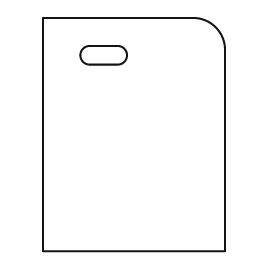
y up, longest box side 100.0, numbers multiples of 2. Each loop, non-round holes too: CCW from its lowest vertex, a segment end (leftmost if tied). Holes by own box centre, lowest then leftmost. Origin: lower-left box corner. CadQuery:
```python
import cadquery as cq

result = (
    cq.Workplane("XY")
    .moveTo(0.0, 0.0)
    .lineTo(78.0, 0.0)
    .lineTo(78.0, 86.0)
    .threePointArc((74.0, 96.0), (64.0, 100.0))
    .lineTo(0.0, 100.0)
    .close()
    .moveTo(20.0, 80.0)
    .lineTo(32.0, 80.0)
    .threePointArc((36.0, 84.0), (32.0, 88.0))
    .lineTo(20.0, 88.0)
    .threePointArc((16.0, 84.0), (20.0, 80.0))
    .close()
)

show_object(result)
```